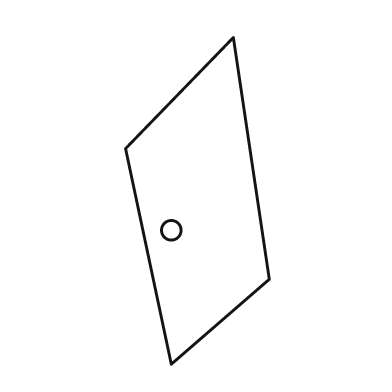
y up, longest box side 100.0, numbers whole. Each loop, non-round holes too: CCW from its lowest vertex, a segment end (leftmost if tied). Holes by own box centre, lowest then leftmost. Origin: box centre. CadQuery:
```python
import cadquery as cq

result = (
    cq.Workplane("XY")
    .moveTo(-8.0, -50.0)
    .lineTo(22.0, -24.0)
    .lineTo(11.0, 50.0)
    .lineTo(-22.0, 16.0)
    .close()
    .moveTo(-8.0, -9.0)
    .circle(3.0)
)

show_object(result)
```